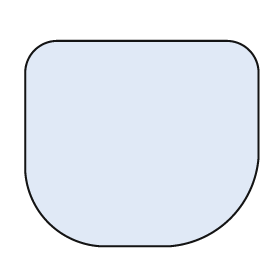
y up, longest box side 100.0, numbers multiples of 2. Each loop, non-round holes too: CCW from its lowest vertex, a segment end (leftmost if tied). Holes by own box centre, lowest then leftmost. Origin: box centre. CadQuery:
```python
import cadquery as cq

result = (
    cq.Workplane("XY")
    .moveTo(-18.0, -44.0)
    .lineTo(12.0, -44.0)
    .threePointArc((38.0, -32.0), (50.0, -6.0))
    .lineTo(50.0, 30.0)
    .threePointArc((46.0, 40.0), (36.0, 44.0))
    .lineTo(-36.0, 44.0)
    .threePointArc((-46.0, 40.0), (-50.0, 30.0))
    .lineTo(-50.0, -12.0)
    .threePointArc((-40.0, -34.0), (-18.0, -44.0))
    .close()
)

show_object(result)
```